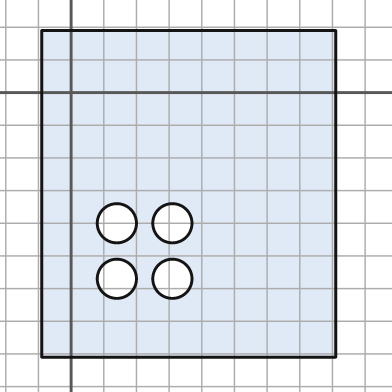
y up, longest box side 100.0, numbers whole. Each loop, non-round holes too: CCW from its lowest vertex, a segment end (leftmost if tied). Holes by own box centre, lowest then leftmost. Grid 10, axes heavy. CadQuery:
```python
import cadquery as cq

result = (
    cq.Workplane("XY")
    .moveTo(-9.0, -81.0)
    .lineTo(81.0, -81.0)
    .lineTo(81.0, 19.0)
    .lineTo(-9.0, 19.0)
    .close()
    .moveTo(14.0, -57.0)
    .circle(6.0)
    .moveTo(31.0, -57.0)
    .circle(6.0)
    .moveTo(14.0, -40.0)
    .circle(6.0)
    .moveTo(31.0, -40.0)
    .circle(6.0)
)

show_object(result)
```